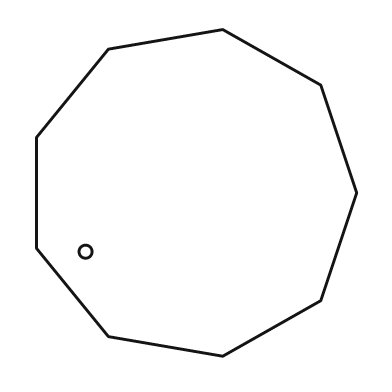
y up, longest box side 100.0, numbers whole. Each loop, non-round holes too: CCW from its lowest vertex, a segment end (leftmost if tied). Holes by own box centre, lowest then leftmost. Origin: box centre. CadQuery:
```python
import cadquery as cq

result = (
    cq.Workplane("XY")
    .moveTo(8.0, -50.0)
    .lineTo(38.0, -33.0)
    .lineTo(49.0, 0.0)
    .lineTo(38.0, 33.0)
    .lineTo(8.0, 50.0)
    .lineTo(-27.0, 44.0)
    .lineTo(-49.0, 17.0)
    .lineTo(-49.0, -17.0)
    .lineTo(-27.0, -44.0)
    .close()
    .moveTo(-34.0, -18.0)
    .circle(2.0)
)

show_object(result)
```